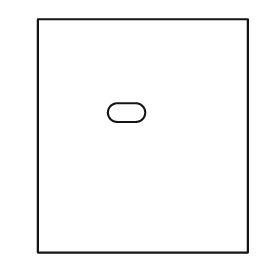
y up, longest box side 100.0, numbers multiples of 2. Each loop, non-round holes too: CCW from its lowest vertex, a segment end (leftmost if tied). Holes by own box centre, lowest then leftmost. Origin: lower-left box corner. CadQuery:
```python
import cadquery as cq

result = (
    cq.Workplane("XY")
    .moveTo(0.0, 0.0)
    .lineTo(90.0, 0.0)
    .lineTo(90.0, 100.0)
    .lineTo(0.0, 100.0)
    .close()
    .moveTo(34.0, 56.0)
    .lineTo(42.0, 56.0)
    .threePointArc((46.0, 60.0), (42.0, 64.0))
    .lineTo(34.0, 64.0)
    .threePointArc((30.0, 60.0), (34.0, 56.0))
    .close()
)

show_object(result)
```